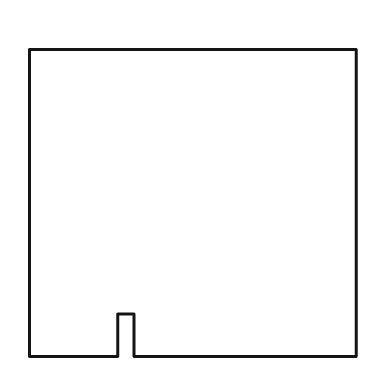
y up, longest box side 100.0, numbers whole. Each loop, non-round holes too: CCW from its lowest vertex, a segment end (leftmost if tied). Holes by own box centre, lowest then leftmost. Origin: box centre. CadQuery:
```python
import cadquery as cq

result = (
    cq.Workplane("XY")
    .moveTo(-50.0, -47.0)
    .lineTo(-23.0, -47.0)
    .lineTo(-23.0, -34.0)
    .lineTo(-18.0, -34.0)
    .lineTo(-18.0, -47.0)
    .lineTo(50.0, -47.0)
    .lineTo(50.0, 47.0)
    .lineTo(-50.0, 47.0)
    .close()
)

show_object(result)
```